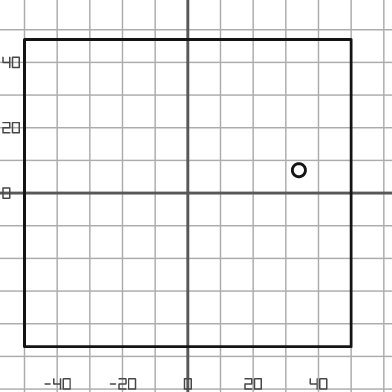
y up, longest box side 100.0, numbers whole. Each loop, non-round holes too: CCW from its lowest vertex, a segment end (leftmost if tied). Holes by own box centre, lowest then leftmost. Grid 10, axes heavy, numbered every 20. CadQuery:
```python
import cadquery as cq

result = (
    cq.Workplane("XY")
    .moveTo(-50.0, -47.0)
    .lineTo(50.0, -47.0)
    .lineTo(50.0, 47.0)
    .lineTo(-50.0, 47.0)
    .close()
    .moveTo(34.0, 7.0)
    .circle(2.0)
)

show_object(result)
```